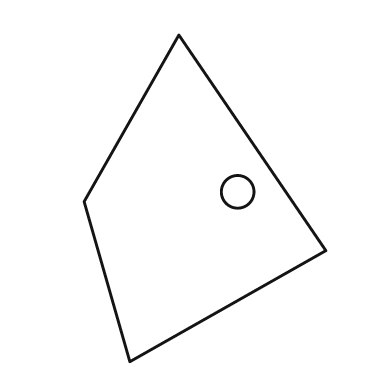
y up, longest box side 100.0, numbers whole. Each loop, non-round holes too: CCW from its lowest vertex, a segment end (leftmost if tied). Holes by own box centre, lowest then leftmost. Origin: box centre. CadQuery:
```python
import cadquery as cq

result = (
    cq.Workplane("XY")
    .moveTo(-23.0, -50.0)
    .lineTo(37.0, -16.0)
    .lineTo(-8.0, 50.0)
    .lineTo(-37.0, -1.0)
    .close()
    .moveTo(10.0, 2.0)
    .circle(5.0)
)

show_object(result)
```